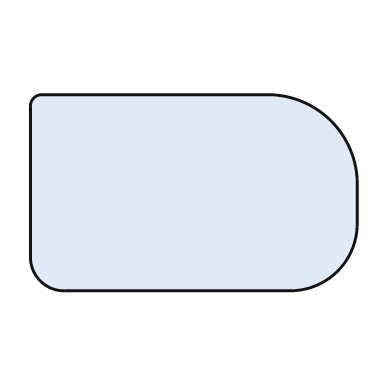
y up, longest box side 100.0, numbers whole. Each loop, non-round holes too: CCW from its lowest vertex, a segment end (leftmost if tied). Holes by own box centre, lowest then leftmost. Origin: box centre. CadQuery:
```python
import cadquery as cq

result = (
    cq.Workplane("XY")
    .moveTo(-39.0, -30.0)
    .lineTo(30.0, -30.0)
    .threePointArc((44.0, -24.0), (50.0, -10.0))
    .lineTo(50.0, 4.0)
    .threePointArc((42.0, 22.0), (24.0, 30.0))
    .lineTo(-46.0, 30.0)
    .threePointArc((-49.0, 29.0), (-50.0, 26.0))
    .lineTo(-50.0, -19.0)
    .threePointArc((-47.0, -27.0), (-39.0, -30.0))
    .close()
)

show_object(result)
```